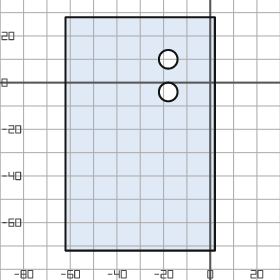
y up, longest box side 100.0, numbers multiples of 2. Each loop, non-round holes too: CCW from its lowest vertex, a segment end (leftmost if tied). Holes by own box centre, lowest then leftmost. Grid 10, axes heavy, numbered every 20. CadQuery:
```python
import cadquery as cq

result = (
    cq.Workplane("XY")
    .moveTo(-62.0, -72.0)
    .lineTo(2.0, -72.0)
    .lineTo(2.0, 28.0)
    .lineTo(-62.0, 28.0)
    .close()
    .moveTo(-18.0, -4.0)
    .circle(4.0)
    .moveTo(-18.0, 10.0)
    .circle(4.0)
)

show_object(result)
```